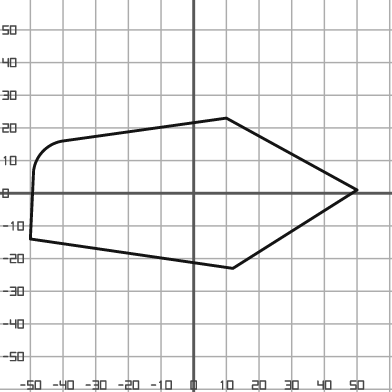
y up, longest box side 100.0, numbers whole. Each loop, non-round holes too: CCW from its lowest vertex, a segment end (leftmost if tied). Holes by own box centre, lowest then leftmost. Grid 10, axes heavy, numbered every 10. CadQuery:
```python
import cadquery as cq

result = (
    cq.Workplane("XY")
    .moveTo(12.0, -23.0)
    .lineTo(50.0, 1.0)
    .lineTo(10.0, 23.0)
    .lineTo(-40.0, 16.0)
    .threePointArc((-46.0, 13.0), (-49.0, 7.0))
    .lineTo(-50.0, -14.0)
    .close()
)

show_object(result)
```